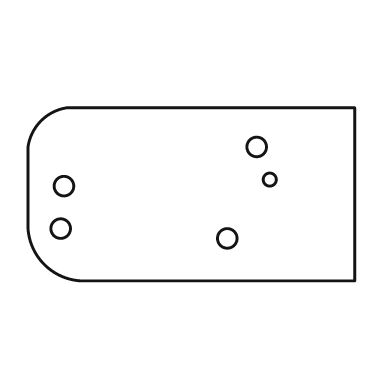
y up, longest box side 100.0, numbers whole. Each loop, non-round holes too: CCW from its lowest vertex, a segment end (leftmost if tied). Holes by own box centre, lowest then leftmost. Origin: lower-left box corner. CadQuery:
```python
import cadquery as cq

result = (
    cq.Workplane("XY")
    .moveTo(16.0, 0.0)
    .lineTo(100.0, 0.0)
    .lineTo(100.0, 53.0)
    .lineTo(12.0, 53.0)
    .threePointArc((4.0, 49.0), (0.0, 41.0))
    .lineTo(0.0, 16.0)
    .threePointArc((5.0, 5.0), (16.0, 0.0))
    .close()
    .moveTo(61.0, 13.0)
    .circle(3.0)
    .moveTo(10.0, 16.0)
    .circle(3.0)
    .moveTo(11.0, 29.0)
    .circle(3.0)
    .moveTo(74.0, 31.0)
    .circle(2.0)
    .moveTo(70.0, 41.0)
    .circle(3.0)
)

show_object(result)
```